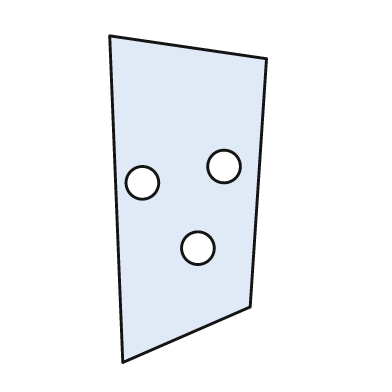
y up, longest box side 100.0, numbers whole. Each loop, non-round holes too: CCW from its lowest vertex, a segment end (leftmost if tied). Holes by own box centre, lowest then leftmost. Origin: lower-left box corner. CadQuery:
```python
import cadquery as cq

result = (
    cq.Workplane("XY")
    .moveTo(4.0, 0.0)
    .lineTo(43.0, 17.0)
    .lineTo(48.0, 93.0)
    .lineTo(0.0, 100.0)
    .close()
    .moveTo(27.0, 35.0)
    .circle(5.0)
    .moveTo(10.0, 55.0)
    .circle(5.0)
    .moveTo(35.0, 60.0)
    .circle(5.0)
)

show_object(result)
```